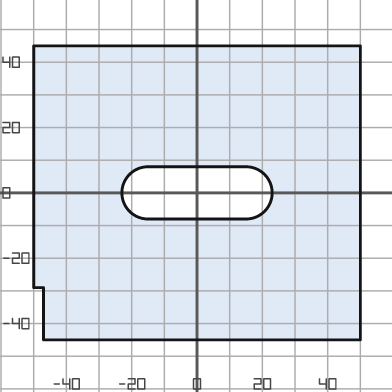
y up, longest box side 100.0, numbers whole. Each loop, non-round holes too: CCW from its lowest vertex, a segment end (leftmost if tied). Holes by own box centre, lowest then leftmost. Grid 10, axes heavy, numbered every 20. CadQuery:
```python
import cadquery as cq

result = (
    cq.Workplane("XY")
    .moveTo(-47.0, -45.0)
    .lineTo(50.0, -45.0)
    .lineTo(50.0, 45.0)
    .lineTo(-50.0, 45.0)
    .lineTo(-50.0, -29.0)
    .lineTo(-47.0, -29.0)
    .close()
    .moveTo(-15.0, -8.0)
    .lineTo(15.0, -8.0)
    .threePointArc((23.0, 0.0), (15.0, 8.0))
    .lineTo(-15.0, 8.0)
    .threePointArc((-23.0, 0.0), (-15.0, -8.0))
    .close()
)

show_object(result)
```